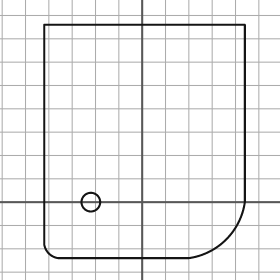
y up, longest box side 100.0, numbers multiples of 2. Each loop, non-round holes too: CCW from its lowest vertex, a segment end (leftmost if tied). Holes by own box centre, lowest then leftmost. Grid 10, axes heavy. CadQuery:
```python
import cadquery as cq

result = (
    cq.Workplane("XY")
    .moveTo(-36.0, -24.0)
    .lineTo(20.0, -24.0)
    .threePointArc((36.0, -16.0), (44.0, 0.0))
    .lineTo(44.0, 76.0)
    .lineTo(-42.0, 76.0)
    .lineTo(-42.0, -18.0)
    .threePointArc((-40.0, -22.0), (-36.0, -24.0))
    .close()
    .moveTo(-22.0, 0.0)
    .circle(4.0)
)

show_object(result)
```